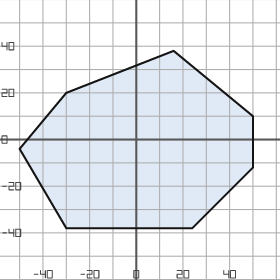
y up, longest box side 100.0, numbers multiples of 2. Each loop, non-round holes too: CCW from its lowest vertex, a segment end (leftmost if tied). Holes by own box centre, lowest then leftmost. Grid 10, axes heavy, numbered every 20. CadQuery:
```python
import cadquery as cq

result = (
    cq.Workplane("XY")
    .moveTo(-30.0, -38.0)
    .lineTo(24.0, -38.0)
    .lineTo(50.0, -12.0)
    .lineTo(50.0, 10.0)
    .lineTo(16.0, 38.0)
    .lineTo(-30.0, 20.0)
    .lineTo(-50.0, -4.0)
    .close()
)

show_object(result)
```